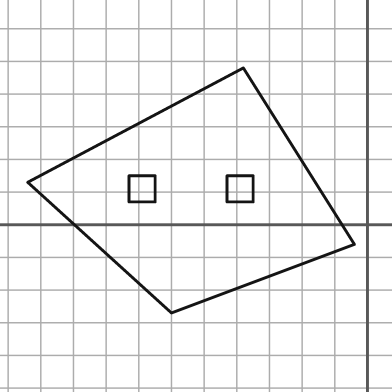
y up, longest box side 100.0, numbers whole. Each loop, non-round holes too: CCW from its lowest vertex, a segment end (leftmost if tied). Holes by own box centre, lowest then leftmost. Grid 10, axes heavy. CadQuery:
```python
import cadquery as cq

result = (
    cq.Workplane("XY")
    .moveTo(-60.0, -27.0)
    .lineTo(-4.0, -6.0)
    .lineTo(-38.0, 48.0)
    .lineTo(-104.0, 13.0)
    .close()
    .moveTo(-73.0, 7.0)
    .lineTo(-65.0, 7.0)
    .lineTo(-65.0, 15.0)
    .lineTo(-73.0, 15.0)
    .close()
    .moveTo(-43.0, 7.0)
    .lineTo(-35.0, 7.0)
    .lineTo(-35.0, 15.0)
    .lineTo(-43.0, 15.0)
    .close()
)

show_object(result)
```